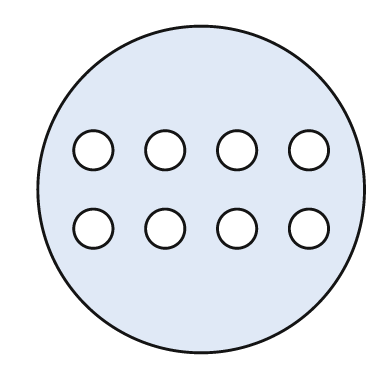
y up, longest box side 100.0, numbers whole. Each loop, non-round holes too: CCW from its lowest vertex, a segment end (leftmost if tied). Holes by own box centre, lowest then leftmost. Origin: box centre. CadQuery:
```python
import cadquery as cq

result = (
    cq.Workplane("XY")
    .moveTo(0.0, 0.0)
    .circle(50.0)
    .moveTo(-33.0, -12.0)
    .circle(6.0)
    .moveTo(-11.0, -12.0)
    .circle(6.0)
    .moveTo(11.0, -12.0)
    .circle(6.0)
    .moveTo(33.0, -12.0)
    .circle(6.0)
    .moveTo(-33.0, 12.0)
    .circle(6.0)
    .moveTo(-11.0, 12.0)
    .circle(6.0)
    .moveTo(11.0, 12.0)
    .circle(6.0)
    .moveTo(33.0, 12.0)
    .circle(6.0)
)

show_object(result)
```